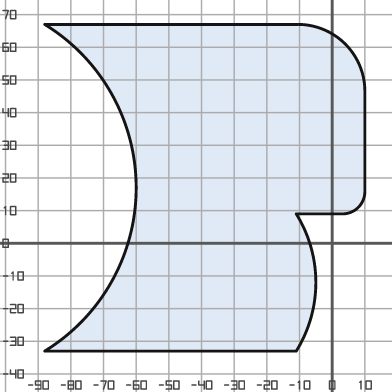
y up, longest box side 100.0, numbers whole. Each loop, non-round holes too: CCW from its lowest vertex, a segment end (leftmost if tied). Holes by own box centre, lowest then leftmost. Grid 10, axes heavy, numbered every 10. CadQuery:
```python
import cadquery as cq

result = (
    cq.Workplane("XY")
    .moveTo(-88.0, -33.0)
    .lineTo(-11.0, -33.0)
    .threePointArc((-5.0, -12.0), (-11.0, 9.0))
    .lineTo(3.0, 9.0)
    .threePointArc((8.0, 11.0), (10.0, 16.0))
    .lineTo(10.0, 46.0)
    .threePointArc((4.0, 61.0), (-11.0, 67.0))
    .lineTo(-88.0, 67.0)
    .threePointArc((-60.0, 17.0), (-88.0, -33.0))
    .close()
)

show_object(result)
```